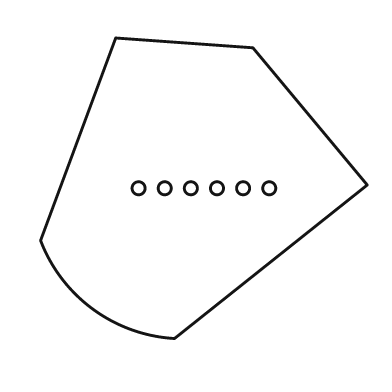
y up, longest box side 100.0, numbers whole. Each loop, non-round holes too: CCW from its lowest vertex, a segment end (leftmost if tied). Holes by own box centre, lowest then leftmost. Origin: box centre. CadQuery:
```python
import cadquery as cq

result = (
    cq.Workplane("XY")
    .moveTo(-9.0, -46.0)
    .lineTo(50.0, 1.0)
    .lineTo(15.0, 43.0)
    .lineTo(-27.0, 46.0)
    .lineTo(-50.0, -16.0)
    .threePointArc((-34.0, -37.0), (-9.0, -46.0))
    .close()
    .moveTo(-20.0, 0.0)
    .circle(2.0)
    .moveTo(-12.0, 0.0)
    .circle(2.0)
    .moveTo(-4.0, 0.0)
    .circle(2.0)
    .moveTo(4.0, 0.0)
    .circle(2.0)
    .moveTo(12.0, 0.0)
    .circle(2.0)
    .moveTo(20.0, 0.0)
    .circle(2.0)
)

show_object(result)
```